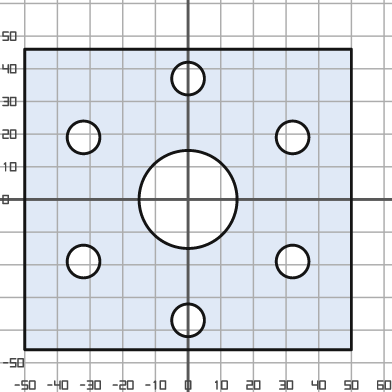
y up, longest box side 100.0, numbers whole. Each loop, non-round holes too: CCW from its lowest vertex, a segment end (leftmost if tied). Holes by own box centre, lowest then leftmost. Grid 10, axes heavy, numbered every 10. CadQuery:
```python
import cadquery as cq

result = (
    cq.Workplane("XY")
    .moveTo(-50.0, -46.0)
    .lineTo(50.0, -46.0)
    .lineTo(50.0, 46.0)
    .lineTo(-50.0, 46.0)
    .close()
    .moveTo(0.0, -37.0)
    .circle(5.0)
    .moveTo(-32.0, -19.0)
    .circle(5.0)
    .moveTo(32.0, -19.0)
    .circle(5.0)
    .moveTo(0.0, 0.0)
    .circle(15.0)
    .moveTo(-32.0, 19.0)
    .circle(5.0)
    .moveTo(32.0, 19.0)
    .circle(5.0)
    .moveTo(0.0, 37.0)
    .circle(5.0)
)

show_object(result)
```